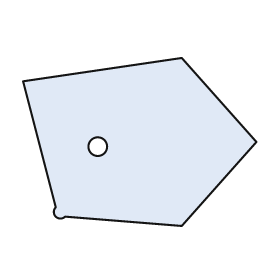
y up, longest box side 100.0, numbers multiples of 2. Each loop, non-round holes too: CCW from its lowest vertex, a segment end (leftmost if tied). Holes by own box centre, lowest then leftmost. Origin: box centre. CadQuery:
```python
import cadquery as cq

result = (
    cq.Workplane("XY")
    .moveTo(18.0, -36.0)
    .lineTo(50.0, 0.0)
    .lineTo(18.0, 36.0)
    .lineTo(-50.0, 26.0)
    .lineTo(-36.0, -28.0)
    .threePointArc((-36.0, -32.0), (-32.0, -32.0))
    .close()
    .moveTo(-18.0, -2.0)
    .circle(4.0)
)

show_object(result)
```